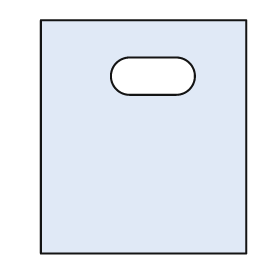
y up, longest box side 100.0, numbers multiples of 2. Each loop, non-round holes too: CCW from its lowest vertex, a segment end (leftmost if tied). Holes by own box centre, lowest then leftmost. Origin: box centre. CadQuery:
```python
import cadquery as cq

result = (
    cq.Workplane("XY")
    .moveTo(-44.0, -50.0)
    .lineTo(44.0, -50.0)
    .lineTo(44.0, 50.0)
    .lineTo(-44.0, 50.0)
    .close()
    .moveTo(-6.0, 18.0)
    .lineTo(14.0, 18.0)
    .threePointArc((22.0, 26.0), (14.0, 34.0))
    .lineTo(-6.0, 34.0)
    .threePointArc((-14.0, 26.0), (-6.0, 18.0))
    .close()
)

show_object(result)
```